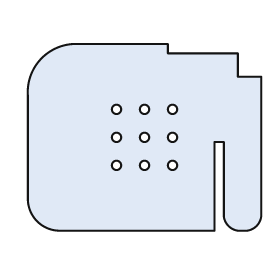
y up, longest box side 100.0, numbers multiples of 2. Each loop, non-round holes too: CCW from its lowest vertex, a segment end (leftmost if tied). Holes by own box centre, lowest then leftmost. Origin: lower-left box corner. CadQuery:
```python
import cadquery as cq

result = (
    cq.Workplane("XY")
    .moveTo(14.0, 0.0)
    .lineTo(80.0, 0.0)
    .lineTo(80.0, 38.0)
    .lineTo(84.0, 38.0)
    .lineTo(84.0, 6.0)
    .threePointArc((86.0, 2.0), (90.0, 0.0))
    .lineTo(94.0, 0.0)
    .threePointArc((98.0, 2.0), (100.0, 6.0))
    .lineTo(100.0, 66.0)
    .lineTo(90.0, 66.0)
    .lineTo(90.0, 76.0)
    .lineTo(60.0, 76.0)
    .lineTo(60.0, 80.0)
    .lineTo(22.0, 80.0)
    .threePointArc((6.0, 74.0), (0.0, 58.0))
    .lineTo(0.0, 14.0)
    .threePointArc((4.0, 4.0), (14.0, 0.0))
    .close()
    .moveTo(38.0, 28.0)
    .circle(2.0)
    .moveTo(50.0, 28.0)
    .circle(2.0)
    .moveTo(62.0, 28.0)
    .circle(2.0)
    .moveTo(38.0, 40.0)
    .circle(2.0)
    .moveTo(50.0, 40.0)
    .circle(2.0)
    .moveTo(62.0, 40.0)
    .circle(2.0)
    .moveTo(38.0, 52.0)
    .circle(2.0)
    .moveTo(50.0, 52.0)
    .circle(2.0)
    .moveTo(62.0, 52.0)
    .circle(2.0)
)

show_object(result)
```